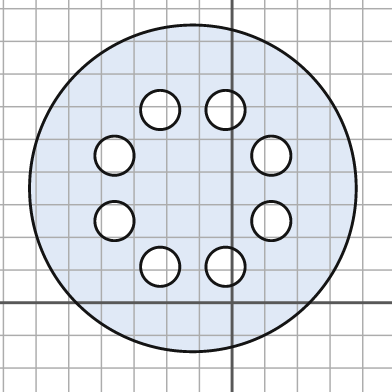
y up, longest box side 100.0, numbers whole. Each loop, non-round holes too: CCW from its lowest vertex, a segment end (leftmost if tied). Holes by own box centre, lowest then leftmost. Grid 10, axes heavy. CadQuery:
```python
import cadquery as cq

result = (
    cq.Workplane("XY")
    .moveTo(-12.0, 35.0)
    .circle(50.0)
    .moveTo(-22.0, 11.0)
    .circle(6.0)
    .moveTo(-2.0, 11.0)
    .circle(6.0)
    .moveTo(-36.0, 25.0)
    .circle(6.0)
    .moveTo(12.0, 25.0)
    .circle(6.0)
    .moveTo(-36.0, 45.0)
    .circle(6.0)
    .moveTo(12.0, 45.0)
    .circle(6.0)
    .moveTo(-22.0, 59.0)
    .circle(6.0)
    .moveTo(-2.0, 59.0)
    .circle(6.0)
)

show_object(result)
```